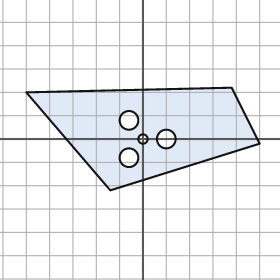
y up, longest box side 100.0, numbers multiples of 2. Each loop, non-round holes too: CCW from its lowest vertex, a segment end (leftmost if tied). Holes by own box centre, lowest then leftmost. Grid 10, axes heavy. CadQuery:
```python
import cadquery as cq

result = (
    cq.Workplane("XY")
    .moveTo(-14.0, -22.0)
    .lineTo(50.0, -2.0)
    .lineTo(38.0, 22.0)
    .lineTo(-50.0, 20.0)
    .close()
    .moveTo(-6.0, -8.0)
    .circle(4.0)
    .moveTo(0.0, 0.0)
    .circle(2.0)
    .moveTo(10.0, 0.0)
    .circle(4.0)
    .moveTo(-6.0, 8.0)
    .circle(4.0)
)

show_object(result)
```